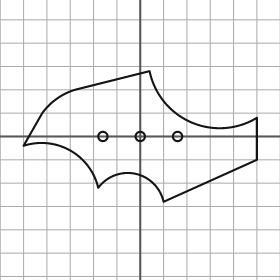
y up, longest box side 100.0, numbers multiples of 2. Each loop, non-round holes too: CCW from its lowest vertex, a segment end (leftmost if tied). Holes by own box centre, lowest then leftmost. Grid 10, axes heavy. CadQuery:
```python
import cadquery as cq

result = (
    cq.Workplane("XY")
    .moveTo(10.0, -28.0)
    .lineTo(50.0, -10.0)
    .lineTo(50.0, 8.0)
    .threePointArc((22.0, 6.0), (4.0, 28.0))
    .lineTo(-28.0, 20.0)
    .threePointArc((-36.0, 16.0), (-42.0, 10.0))
    .lineTo(-50.0, -4.0)
    .threePointArc((-30.0, -6.0), (-18.0, -22.0))
    .threePointArc((-2.0, -16.0), (10.0, -28.0))
    .close()
    .moveTo(-16.0, 0.0)
    .circle(2.0)
    .moveTo(0.0, 0.0)
    .circle(2.0)
    .moveTo(16.0, 0.0)
    .circle(2.0)
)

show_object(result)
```